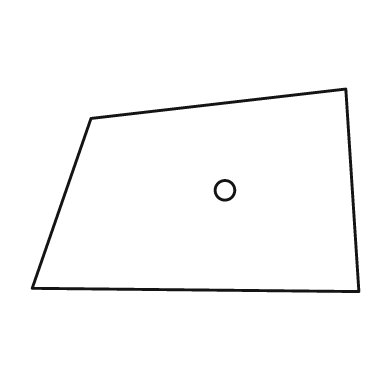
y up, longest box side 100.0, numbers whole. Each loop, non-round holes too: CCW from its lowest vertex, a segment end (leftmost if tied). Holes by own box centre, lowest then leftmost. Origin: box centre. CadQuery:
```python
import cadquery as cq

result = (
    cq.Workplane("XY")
    .moveTo(50.0, -31.0)
    .lineTo(46.0, 31.0)
    .lineTo(-32.0, 22.0)
    .lineTo(-50.0, -30.0)
    .close()
    .moveTo(9.0, 0.0)
    .circle(3.0)
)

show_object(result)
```